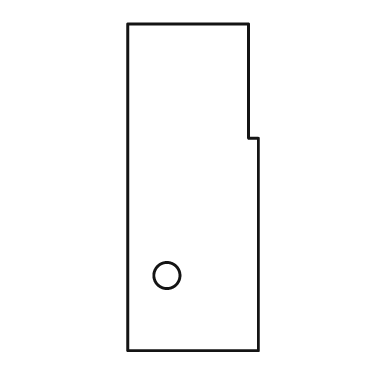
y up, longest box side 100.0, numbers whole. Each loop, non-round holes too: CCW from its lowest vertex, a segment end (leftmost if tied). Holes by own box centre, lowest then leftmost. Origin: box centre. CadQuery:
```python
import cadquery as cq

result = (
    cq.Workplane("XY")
    .moveTo(-20.0, -50.0)
    .lineTo(20.0, -50.0)
    .lineTo(20.0, 15.0)
    .lineTo(17.0, 15.0)
    .lineTo(17.0, 50.0)
    .lineTo(-20.0, 50.0)
    .close()
    .moveTo(-8.0, -27.0)
    .circle(4.0)
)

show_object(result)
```